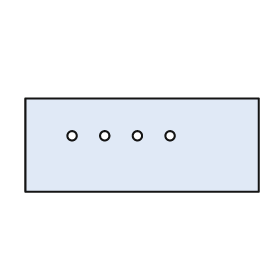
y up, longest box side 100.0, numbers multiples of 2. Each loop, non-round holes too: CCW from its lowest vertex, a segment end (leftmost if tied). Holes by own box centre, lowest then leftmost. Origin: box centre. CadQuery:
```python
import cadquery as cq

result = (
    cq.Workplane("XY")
    .moveTo(-50.0, -20.0)
    .lineTo(50.0, -20.0)
    .lineTo(50.0, 20.0)
    .lineTo(-50.0, 20.0)
    .close()
    .moveTo(-30.0, 4.0)
    .circle(2.0)
    .moveTo(-16.0, 4.0)
    .circle(2.0)
    .moveTo(-2.0, 4.0)
    .circle(2.0)
    .moveTo(12.0, 4.0)
    .circle(2.0)
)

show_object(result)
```